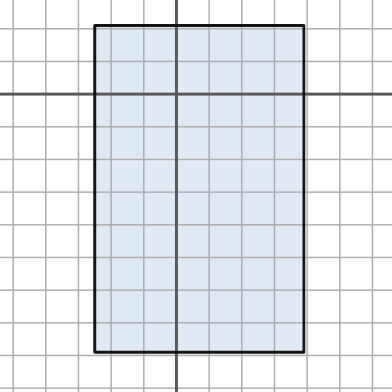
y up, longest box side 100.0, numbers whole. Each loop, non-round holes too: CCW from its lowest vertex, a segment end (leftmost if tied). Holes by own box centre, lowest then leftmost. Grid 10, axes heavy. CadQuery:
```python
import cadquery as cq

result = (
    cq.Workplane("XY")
    .moveTo(-25.0, -79.0)
    .lineTo(39.0, -79.0)
    .lineTo(39.0, 21.0)
    .lineTo(-25.0, 21.0)
    .close()
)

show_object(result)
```